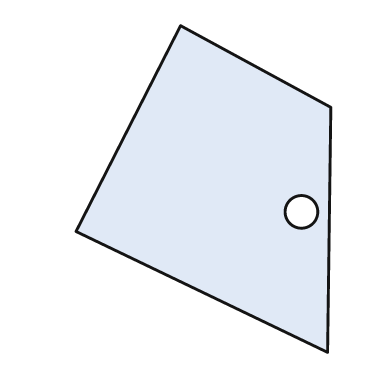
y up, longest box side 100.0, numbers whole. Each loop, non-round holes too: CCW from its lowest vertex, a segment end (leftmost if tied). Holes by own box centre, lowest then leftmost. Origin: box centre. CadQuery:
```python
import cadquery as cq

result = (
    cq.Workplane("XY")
    .moveTo(38.0, -50.0)
    .lineTo(39.0, 25.0)
    .lineTo(-7.0, 50.0)
    .lineTo(-39.0, -13.0)
    .close()
    .moveTo(30.0, -7.0)
    .circle(5.0)
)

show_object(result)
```